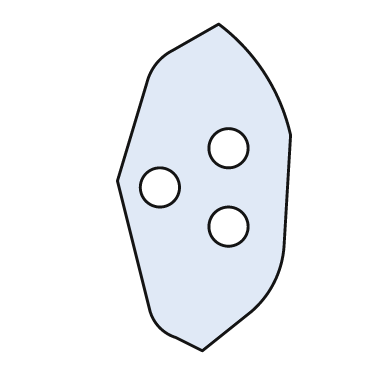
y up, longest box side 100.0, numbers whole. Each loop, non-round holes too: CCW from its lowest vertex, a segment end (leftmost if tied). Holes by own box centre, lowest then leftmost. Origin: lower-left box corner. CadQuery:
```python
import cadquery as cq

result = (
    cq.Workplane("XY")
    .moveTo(26.0, 0.0)
    .lineTo(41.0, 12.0)
    .threePointArc((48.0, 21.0), (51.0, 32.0))
    .lineTo(53.0, 66.0)
    .threePointArc((45.0, 85.0), (31.0, 100.0))
    .lineTo(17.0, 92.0)
    .threePointArc((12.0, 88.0), (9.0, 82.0))
    .lineTo(0.0, 52.0)
    .lineTo(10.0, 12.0)
    .threePointArc((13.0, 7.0), (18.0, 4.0))
    .close()
    .moveTo(34.0, 38.0)
    .circle(6.0)
    .moveTo(13.0, 50.0)
    .circle(6.0)
    .moveTo(34.0, 62.0)
    .circle(6.0)
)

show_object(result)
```